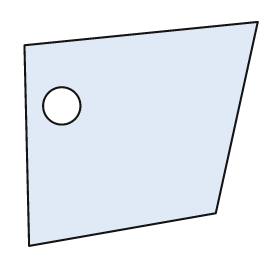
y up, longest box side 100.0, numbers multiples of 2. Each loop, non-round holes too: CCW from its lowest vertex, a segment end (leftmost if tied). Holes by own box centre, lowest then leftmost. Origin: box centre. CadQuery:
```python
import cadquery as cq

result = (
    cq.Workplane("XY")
    .moveTo(-48.0, -48.0)
    .lineTo(32.0, -34.0)
    .lineTo(50.0, 48.0)
    .lineTo(-50.0, 38.0)
    .close()
    .moveTo(-34.0, 12.0)
    .circle(8.0)
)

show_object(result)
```